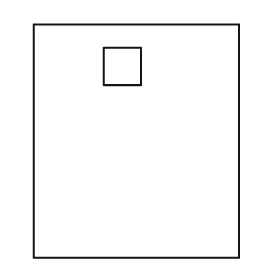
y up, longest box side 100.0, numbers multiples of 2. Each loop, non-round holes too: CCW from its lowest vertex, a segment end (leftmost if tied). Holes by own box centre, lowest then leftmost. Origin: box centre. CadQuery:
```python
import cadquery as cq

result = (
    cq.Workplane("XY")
    .moveTo(-44.0, -50.0)
    .lineTo(44.0, -50.0)
    .lineTo(44.0, 50.0)
    .lineTo(-44.0, 50.0)
    .close()
    .moveTo(-14.0, 24.0)
    .lineTo(2.0, 24.0)
    .lineTo(2.0, 40.0)
    .lineTo(-14.0, 40.0)
    .close()
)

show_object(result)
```